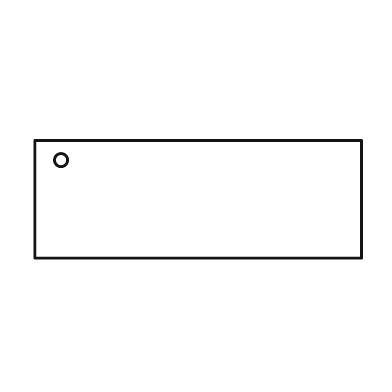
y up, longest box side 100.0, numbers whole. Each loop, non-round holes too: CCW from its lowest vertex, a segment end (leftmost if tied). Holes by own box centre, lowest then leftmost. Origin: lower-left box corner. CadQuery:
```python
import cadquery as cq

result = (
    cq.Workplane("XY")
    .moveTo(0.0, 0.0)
    .lineTo(100.0, 0.0)
    .lineTo(100.0, 36.0)
    .lineTo(0.0, 36.0)
    .close()
    .moveTo(8.0, 30.0)
    .circle(2.0)
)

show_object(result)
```